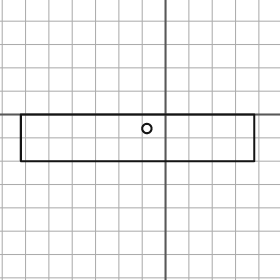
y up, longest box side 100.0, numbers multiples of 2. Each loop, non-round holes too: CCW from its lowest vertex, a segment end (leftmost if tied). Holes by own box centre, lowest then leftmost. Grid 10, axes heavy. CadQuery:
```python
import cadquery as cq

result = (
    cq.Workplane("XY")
    .moveTo(-62.0, -20.0)
    .lineTo(38.0, -20.0)
    .lineTo(38.0, 0.0)
    .lineTo(-62.0, 0.0)
    .close()
    .moveTo(-8.0, -6.0)
    .circle(2.0)
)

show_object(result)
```